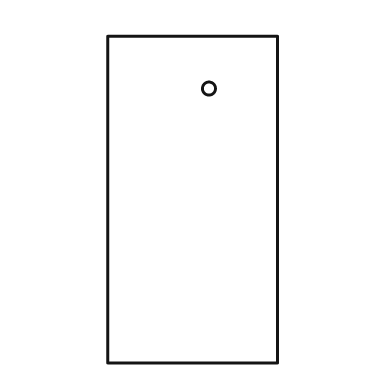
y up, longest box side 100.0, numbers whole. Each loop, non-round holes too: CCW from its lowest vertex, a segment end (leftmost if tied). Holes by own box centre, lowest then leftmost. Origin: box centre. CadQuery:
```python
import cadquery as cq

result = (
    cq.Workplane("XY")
    .moveTo(-26.0, -50.0)
    .lineTo(26.0, -50.0)
    .lineTo(26.0, 50.0)
    .lineTo(-26.0, 50.0)
    .close()
    .moveTo(5.0, 34.0)
    .circle(2.0)
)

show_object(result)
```